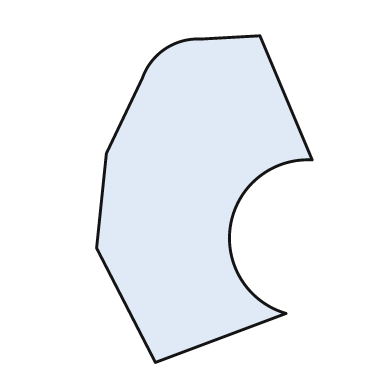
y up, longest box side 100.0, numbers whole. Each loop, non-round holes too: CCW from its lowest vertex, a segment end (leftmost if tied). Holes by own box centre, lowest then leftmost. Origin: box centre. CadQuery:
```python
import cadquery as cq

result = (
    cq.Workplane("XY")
    .moveTo(-15.0, -50.0)
    .lineTo(25.0, -35.0)
    .threePointArc((8.0, -8.0), (33.0, 12.0))
    .lineTo(17.0, 50.0)
    .lineTo(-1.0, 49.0)
    .threePointArc((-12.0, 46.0), (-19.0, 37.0))
    .lineTo(-30.0, 14.0)
    .lineTo(-33.0, -15.0)
    .close()
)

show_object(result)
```